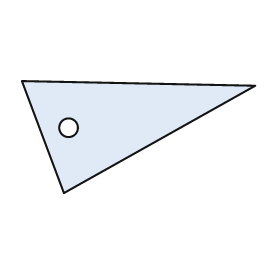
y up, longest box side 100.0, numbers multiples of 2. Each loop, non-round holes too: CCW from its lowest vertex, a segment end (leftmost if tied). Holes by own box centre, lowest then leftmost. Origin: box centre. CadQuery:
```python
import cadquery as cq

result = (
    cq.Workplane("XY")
    .moveTo(-32.0, -24.0)
    .lineTo(50.0, 22.0)
    .lineTo(-50.0, 24.0)
    .close()
    .moveTo(-30.0, 4.0)
    .circle(4.0)
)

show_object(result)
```